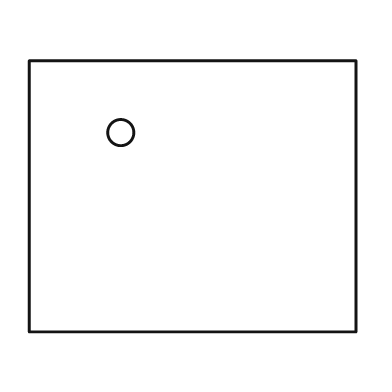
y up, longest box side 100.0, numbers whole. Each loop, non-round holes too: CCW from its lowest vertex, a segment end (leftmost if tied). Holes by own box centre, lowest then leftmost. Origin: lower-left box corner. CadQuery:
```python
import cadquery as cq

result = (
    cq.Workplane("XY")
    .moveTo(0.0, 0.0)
    .lineTo(100.0, 0.0)
    .lineTo(100.0, 83.0)
    .lineTo(0.0, 83.0)
    .close()
    .moveTo(28.0, 61.0)
    .circle(4.0)
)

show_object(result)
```